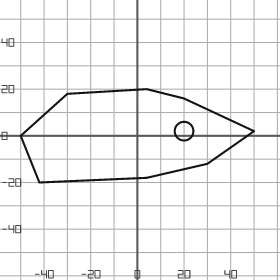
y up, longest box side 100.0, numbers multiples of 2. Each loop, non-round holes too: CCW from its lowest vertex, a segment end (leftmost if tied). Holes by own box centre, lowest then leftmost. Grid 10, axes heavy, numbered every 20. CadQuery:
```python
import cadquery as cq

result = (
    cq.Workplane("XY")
    .moveTo(-42.0, -20.0)
    .lineTo(4.0, -18.0)
    .lineTo(30.0, -12.0)
    .lineTo(50.0, 2.0)
    .lineTo(20.0, 16.0)
    .lineTo(4.0, 20.0)
    .lineTo(-30.0, 18.0)
    .lineTo(-50.0, 0.0)
    .close()
    .moveTo(20.0, 2.0)
    .circle(4.0)
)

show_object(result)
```